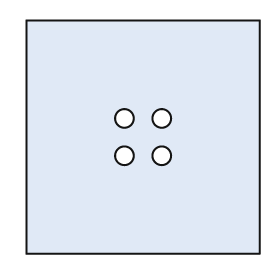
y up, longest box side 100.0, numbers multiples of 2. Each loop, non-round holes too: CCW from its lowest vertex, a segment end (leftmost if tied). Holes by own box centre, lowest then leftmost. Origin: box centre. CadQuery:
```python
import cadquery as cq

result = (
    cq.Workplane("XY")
    .moveTo(-50.0, -50.0)
    .lineTo(50.0, -50.0)
    .lineTo(50.0, 50.0)
    .lineTo(-50.0, 50.0)
    .close()
    .moveTo(-8.0, -8.0)
    .circle(4.0)
    .moveTo(8.0, -8.0)
    .circle(4.0)
    .moveTo(-8.0, 8.0)
    .circle(4.0)
    .moveTo(8.0, 8.0)
    .circle(4.0)
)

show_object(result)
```